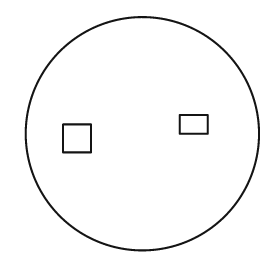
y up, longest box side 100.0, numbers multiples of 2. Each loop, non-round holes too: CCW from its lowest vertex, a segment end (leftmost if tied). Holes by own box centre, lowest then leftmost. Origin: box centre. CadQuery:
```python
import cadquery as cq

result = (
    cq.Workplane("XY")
    .moveTo(0.0, 0.0)
    .circle(50.0)
    .moveTo(-34.0, -8.0)
    .lineTo(-22.0, -8.0)
    .lineTo(-22.0, 4.0)
    .lineTo(-34.0, 4.0)
    .close()
    .moveTo(16.0, 0.0)
    .lineTo(28.0, 0.0)
    .lineTo(28.0, 8.0)
    .lineTo(16.0, 8.0)
    .close()
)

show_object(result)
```